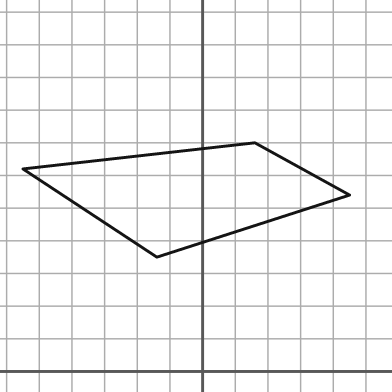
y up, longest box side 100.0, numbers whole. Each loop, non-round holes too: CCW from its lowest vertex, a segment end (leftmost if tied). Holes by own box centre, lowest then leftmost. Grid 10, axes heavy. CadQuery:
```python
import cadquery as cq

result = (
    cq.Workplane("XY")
    .moveTo(-14.0, 35.0)
    .lineTo(45.0, 54.0)
    .lineTo(16.0, 70.0)
    .lineTo(-55.0, 62.0)
    .close()
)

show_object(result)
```